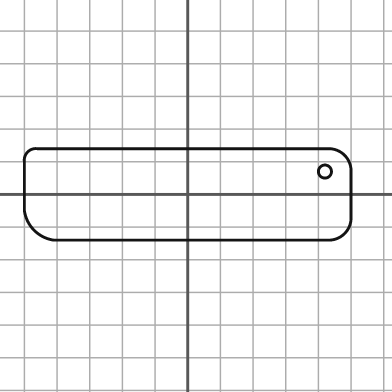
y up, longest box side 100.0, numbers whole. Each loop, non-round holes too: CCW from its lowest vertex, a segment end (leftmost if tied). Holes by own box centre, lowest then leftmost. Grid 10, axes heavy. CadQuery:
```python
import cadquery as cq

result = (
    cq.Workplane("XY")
    .moveTo(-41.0, -14.0)
    .lineTo(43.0, -14.0)
    .threePointArc((48.0, -12.0), (50.0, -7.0))
    .lineTo(50.0, 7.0)
    .threePointArc((48.0, 12.0), (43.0, 14.0))
    .lineTo(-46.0, 14.0)
    .threePointArc((-49.0, 13.0), (-50.0, 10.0))
    .lineTo(-50.0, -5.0)
    .threePointArc((-47.0, -11.0), (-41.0, -14.0))
    .close()
    .moveTo(42.0, 7.0)
    .circle(2.0)
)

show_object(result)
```